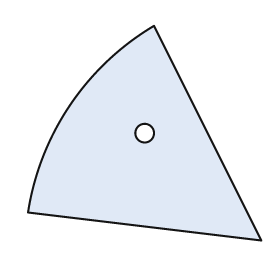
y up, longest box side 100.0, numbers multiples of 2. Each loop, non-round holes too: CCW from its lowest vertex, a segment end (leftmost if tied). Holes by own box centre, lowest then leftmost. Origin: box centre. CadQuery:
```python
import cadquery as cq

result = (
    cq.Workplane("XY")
    .moveTo(50.0, -46.0)
    .lineTo(4.0, 46.0)
    .threePointArc((-32.0, 12.0), (-50.0, -34.0))
    .close()
    .moveTo(0.0, 0.0)
    .circle(4.0)
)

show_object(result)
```